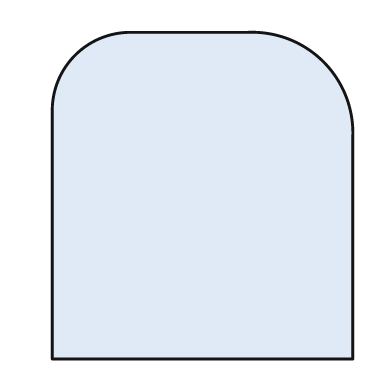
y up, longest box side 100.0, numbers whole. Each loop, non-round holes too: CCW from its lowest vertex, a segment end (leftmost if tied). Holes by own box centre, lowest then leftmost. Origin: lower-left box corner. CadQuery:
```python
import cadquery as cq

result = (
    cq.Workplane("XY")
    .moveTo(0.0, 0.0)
    .lineTo(92.0, 0.0)
    .lineTo(92.0, 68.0)
    .threePointArc((83.0, 91.0), (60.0, 100.0))
    .lineTo(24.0, 100.0)
    .threePointArc((7.0, 93.0), (0.0, 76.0))
    .close()
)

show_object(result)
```